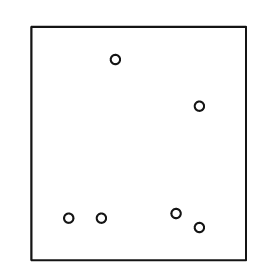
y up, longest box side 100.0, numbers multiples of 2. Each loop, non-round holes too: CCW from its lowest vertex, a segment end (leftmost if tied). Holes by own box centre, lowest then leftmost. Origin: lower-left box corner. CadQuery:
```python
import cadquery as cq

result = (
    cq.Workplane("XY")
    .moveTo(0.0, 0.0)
    .lineTo(92.0, 0.0)
    .lineTo(92.0, 100.0)
    .lineTo(0.0, 100.0)
    .close()
    .moveTo(72.0, 14.0)
    .circle(2.0)
    .moveTo(16.0, 18.0)
    .circle(2.0)
    .moveTo(30.0, 18.0)
    .circle(2.0)
    .moveTo(62.0, 20.0)
    .circle(2.0)
    .moveTo(72.0, 66.0)
    .circle(2.0)
    .moveTo(36.0, 86.0)
    .circle(2.0)
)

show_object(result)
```